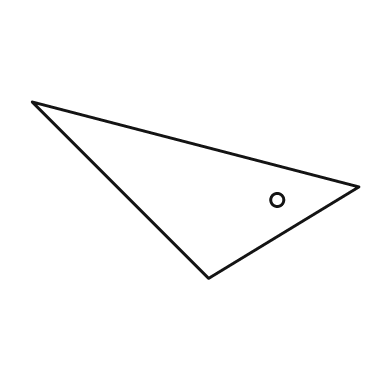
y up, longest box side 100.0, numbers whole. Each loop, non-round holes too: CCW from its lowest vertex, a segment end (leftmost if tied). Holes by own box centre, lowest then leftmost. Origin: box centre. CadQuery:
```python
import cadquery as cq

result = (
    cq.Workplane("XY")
    .moveTo(4.0, -27.0)
    .lineTo(50.0, 1.0)
    .lineTo(-50.0, 27.0)
    .close()
    .moveTo(25.0, -3.0)
    .circle(2.0)
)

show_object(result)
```